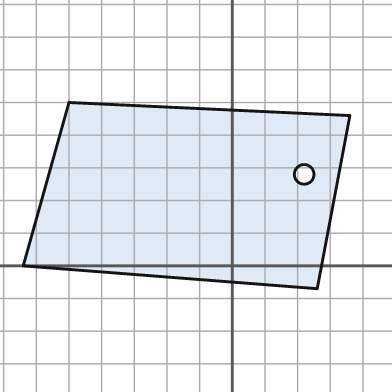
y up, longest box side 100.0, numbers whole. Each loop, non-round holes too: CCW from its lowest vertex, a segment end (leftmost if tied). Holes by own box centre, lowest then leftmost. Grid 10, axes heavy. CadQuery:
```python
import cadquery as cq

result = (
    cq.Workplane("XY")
    .moveTo(26.0, -7.0)
    .lineTo(36.0, 46.0)
    .lineTo(-50.0, 50.0)
    .lineTo(-64.0, 0.0)
    .close()
    .moveTo(22.0, 28.0)
    .circle(3.0)
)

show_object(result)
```